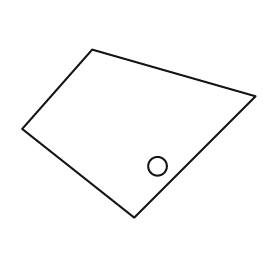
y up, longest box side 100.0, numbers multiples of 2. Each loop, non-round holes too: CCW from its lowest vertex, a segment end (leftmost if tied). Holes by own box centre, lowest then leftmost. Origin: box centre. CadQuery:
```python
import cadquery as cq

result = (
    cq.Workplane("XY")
    .moveTo(-2.0, -36.0)
    .lineTo(50.0, 16.0)
    .lineTo(-20.0, 36.0)
    .lineTo(-50.0, 2.0)
    .close()
    .moveTo(8.0, -14.0)
    .circle(4.0)
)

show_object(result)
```